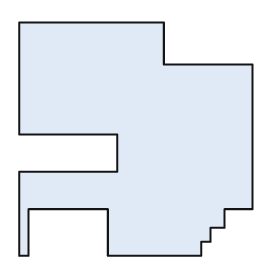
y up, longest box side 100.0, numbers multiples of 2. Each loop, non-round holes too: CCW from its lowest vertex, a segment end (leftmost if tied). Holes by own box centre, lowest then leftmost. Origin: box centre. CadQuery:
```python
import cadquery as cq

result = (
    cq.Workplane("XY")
    .moveTo(-50.0, -50.0)
    .lineTo(-46.0, -50.0)
    .lineTo(-46.0, -30.0)
    .lineTo(-12.0, -30.0)
    .lineTo(-12.0, -50.0)
    .lineTo(28.0, -50.0)
    .lineTo(28.0, -44.0)
    .lineTo(32.0, -44.0)
    .lineTo(32.0, -38.0)
    .lineTo(38.0, -38.0)
    .lineTo(38.0, -30.0)
    .lineTo(50.0, -30.0)
    .lineTo(50.0, 32.0)
    .lineTo(12.0, 32.0)
    .lineTo(12.0, 50.0)
    .lineTo(-50.0, 50.0)
    .lineTo(-50.0, 2.0)
    .lineTo(-8.0, 2.0)
    .lineTo(-8.0, -14.0)
    .lineTo(-50.0, -14.0)
    .close()
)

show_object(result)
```